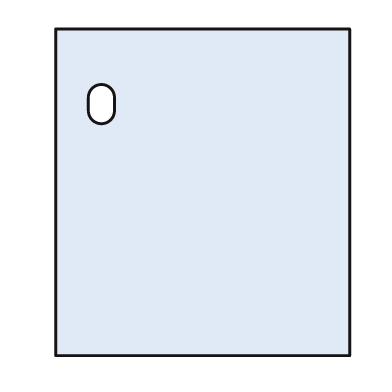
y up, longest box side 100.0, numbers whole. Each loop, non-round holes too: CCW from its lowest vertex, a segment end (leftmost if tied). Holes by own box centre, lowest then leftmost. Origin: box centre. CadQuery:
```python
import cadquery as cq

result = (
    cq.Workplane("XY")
    .moveTo(-45.0, -50.0)
    .lineTo(45.0, -50.0)
    .lineTo(45.0, 50.0)
    .lineTo(-45.0, 50.0)
    .close()
    .moveTo(-35.0, 25.0)
    .threePointArc((-31.0, 21.0), (-27.0, 25.0))
    .lineTo(-27.0, 29.0)
    .threePointArc((-31.0, 33.0), (-35.0, 29.0))
    .close()
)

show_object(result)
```